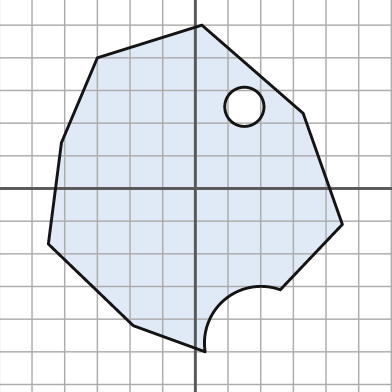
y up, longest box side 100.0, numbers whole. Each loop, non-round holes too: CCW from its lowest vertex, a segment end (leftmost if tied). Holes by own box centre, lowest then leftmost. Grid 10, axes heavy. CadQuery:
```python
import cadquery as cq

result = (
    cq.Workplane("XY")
    .moveTo(3.0, -50.0)
    .threePointArc((9.0, -34.0), (26.0, -31.0))
    .lineTo(45.0, -11.0)
    .lineTo(33.0, 23.0)
    .lineTo(2.0, 50.0)
    .lineTo(-30.0, 40.0)
    .lineTo(-41.0, 14.0)
    .lineTo(-45.0, -17.0)
    .lineTo(-19.0, -42.0)
    .close()
    .moveTo(15.0, 25.0)
    .circle(6.0)
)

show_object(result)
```